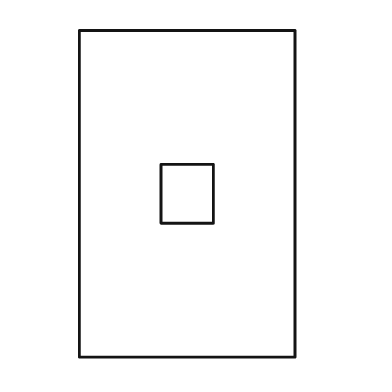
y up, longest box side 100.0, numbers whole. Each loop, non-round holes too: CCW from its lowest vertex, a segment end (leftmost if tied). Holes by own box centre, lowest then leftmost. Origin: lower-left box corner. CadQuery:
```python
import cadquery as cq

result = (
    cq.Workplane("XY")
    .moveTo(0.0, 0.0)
    .lineTo(66.0, 0.0)
    .lineTo(66.0, 100.0)
    .lineTo(0.0, 100.0)
    .close()
    .moveTo(25.0, 41.0)
    .lineTo(41.0, 41.0)
    .lineTo(41.0, 59.0)
    .lineTo(25.0, 59.0)
    .close()
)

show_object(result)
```